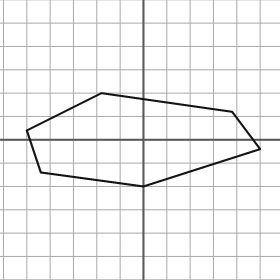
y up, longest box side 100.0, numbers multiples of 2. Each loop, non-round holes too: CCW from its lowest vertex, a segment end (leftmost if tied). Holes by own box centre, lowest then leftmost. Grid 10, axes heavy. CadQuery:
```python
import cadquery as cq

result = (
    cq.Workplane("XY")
    .moveTo(0.0, -20.0)
    .lineTo(50.0, -4.0)
    .lineTo(38.0, 12.0)
    .lineTo(-18.0, 20.0)
    .lineTo(-50.0, 4.0)
    .lineTo(-44.0, -14.0)
    .close()
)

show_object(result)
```